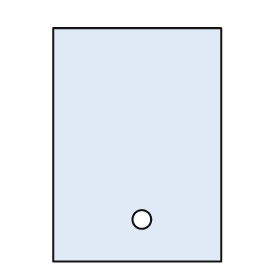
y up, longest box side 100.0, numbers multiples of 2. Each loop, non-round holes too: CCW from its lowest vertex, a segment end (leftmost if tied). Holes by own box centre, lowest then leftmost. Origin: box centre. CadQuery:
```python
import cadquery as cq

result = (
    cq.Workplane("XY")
    .moveTo(-36.0, -50.0)
    .lineTo(36.0, -50.0)
    .lineTo(36.0, 50.0)
    .lineTo(-36.0, 50.0)
    .close()
    .moveTo(2.0, -32.0)
    .circle(4.0)
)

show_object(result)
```